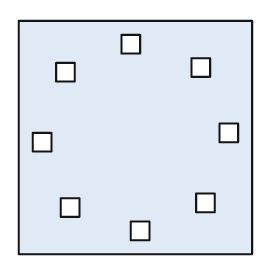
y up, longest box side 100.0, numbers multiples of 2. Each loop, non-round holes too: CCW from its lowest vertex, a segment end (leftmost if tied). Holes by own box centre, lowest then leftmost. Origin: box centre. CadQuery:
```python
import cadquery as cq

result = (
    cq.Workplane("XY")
    .moveTo(-50.0, -50.0)
    .lineTo(50.0, -50.0)
    .lineTo(50.0, 50.0)
    .lineTo(-50.0, 50.0)
    .close()
    .moveTo(-2.0, -44.0)
    .lineTo(6.0, -44.0)
    .lineTo(6.0, -36.0)
    .lineTo(-2.0, -36.0)
    .close()
    .moveTo(-32.0, -34.0)
    .lineTo(-24.0, -34.0)
    .lineTo(-24.0, -26.0)
    .lineTo(-32.0, -26.0)
    .close()
    .moveTo(26.0, -32.0)
    .lineTo(34.0, -32.0)
    .lineTo(34.0, -24.0)
    .lineTo(26.0, -24.0)
    .close()
    .moveTo(-44.0, -6.0)
    .lineTo(-36.0, -6.0)
    .lineTo(-36.0, 2.0)
    .lineTo(-44.0, 2.0)
    .close()
    .moveTo(36.0, -2.0)
    .lineTo(44.0, -2.0)
    .lineTo(44.0, 6.0)
    .lineTo(36.0, 6.0)
    .close()
    .moveTo(-34.0, 24.0)
    .lineTo(-26.0, 24.0)
    .lineTo(-26.0, 32.0)
    .lineTo(-34.0, 32.0)
    .close()
    .moveTo(24.0, 26.0)
    .lineTo(32.0, 26.0)
    .lineTo(32.0, 34.0)
    .lineTo(24.0, 34.0)
    .close()
    .moveTo(-6.0, 36.0)
    .lineTo(2.0, 36.0)
    .lineTo(2.0, 44.0)
    .lineTo(-6.0, 44.0)
    .close()
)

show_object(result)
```